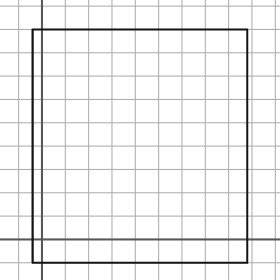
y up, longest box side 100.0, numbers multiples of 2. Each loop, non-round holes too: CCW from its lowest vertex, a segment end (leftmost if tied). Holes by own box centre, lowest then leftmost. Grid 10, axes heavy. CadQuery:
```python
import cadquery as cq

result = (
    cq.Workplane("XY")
    .moveTo(-4.0, -10.0)
    .lineTo(88.0, -10.0)
    .lineTo(88.0, 90.0)
    .lineTo(-4.0, 90.0)
    .close()
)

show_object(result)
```